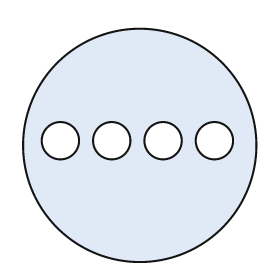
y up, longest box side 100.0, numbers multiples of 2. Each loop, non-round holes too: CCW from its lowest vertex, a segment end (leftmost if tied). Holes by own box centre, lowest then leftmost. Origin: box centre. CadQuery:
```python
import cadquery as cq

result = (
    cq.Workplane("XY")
    .moveTo(0.0, 0.0)
    .circle(50.0)
    .moveTo(-34.0, 2.0)
    .circle(8.0)
    .moveTo(-12.0, 2.0)
    .circle(8.0)
    .moveTo(10.0, 2.0)
    .circle(8.0)
    .moveTo(32.0, 2.0)
    .circle(8.0)
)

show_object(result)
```